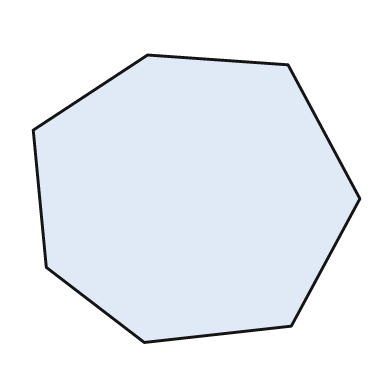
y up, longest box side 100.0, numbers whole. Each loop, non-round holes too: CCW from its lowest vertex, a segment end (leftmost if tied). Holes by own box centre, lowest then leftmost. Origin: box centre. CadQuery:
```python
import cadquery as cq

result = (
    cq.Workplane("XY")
    .moveTo(-16.0, -44.0)
    .lineTo(29.0, -39.0)
    .lineTo(50.0, 0.0)
    .lineTo(28.0, 41.0)
    .lineTo(-15.0, 44.0)
    .lineTo(-50.0, 21.0)
    .lineTo(-46.0, -21.0)
    .close()
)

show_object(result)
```